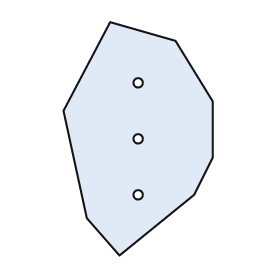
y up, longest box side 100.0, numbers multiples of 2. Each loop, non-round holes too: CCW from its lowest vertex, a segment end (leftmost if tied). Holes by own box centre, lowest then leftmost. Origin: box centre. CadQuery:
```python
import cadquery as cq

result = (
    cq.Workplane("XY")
    .moveTo(-8.0, -50.0)
    .lineTo(24.0, -24.0)
    .lineTo(32.0, -8.0)
    .lineTo(32.0, 16.0)
    .lineTo(16.0, 42.0)
    .lineTo(-12.0, 50.0)
    .lineTo(-32.0, 12.0)
    .lineTo(-22.0, -34.0)
    .close()
    .moveTo(0.0, -24.0)
    .circle(2.0)
    .moveTo(0.0, 0.0)
    .circle(2.0)
    .moveTo(0.0, 24.0)
    .circle(2.0)
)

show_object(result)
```